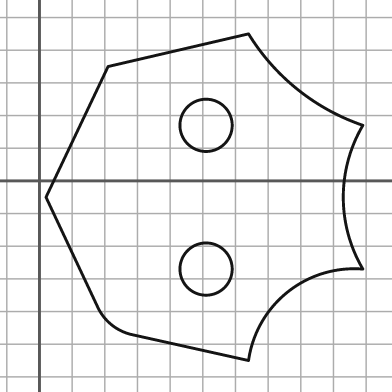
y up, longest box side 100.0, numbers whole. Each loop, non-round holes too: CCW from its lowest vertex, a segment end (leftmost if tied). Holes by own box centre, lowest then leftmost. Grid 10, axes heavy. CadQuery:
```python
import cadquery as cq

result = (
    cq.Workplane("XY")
    .moveTo(64.0, -55.0)
    .threePointArc((76.0, -34.0), (99.0, -27.0))
    .threePointArc((93.0, -5.0), (99.0, 17.0))
    .threePointArc((79.0, 28.0), (64.0, 45.0))
    .lineTo(21.0, 35.0)
    .lineTo(2.0, -5.0)
    .lineTo(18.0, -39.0)
    .threePointArc((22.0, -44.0), (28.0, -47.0))
    .close()
    .moveTo(51.0, -27.0)
    .circle(8.0)
    .moveTo(51.0, 17.0)
    .circle(8.0)
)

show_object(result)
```